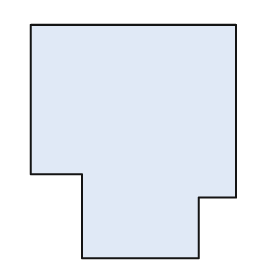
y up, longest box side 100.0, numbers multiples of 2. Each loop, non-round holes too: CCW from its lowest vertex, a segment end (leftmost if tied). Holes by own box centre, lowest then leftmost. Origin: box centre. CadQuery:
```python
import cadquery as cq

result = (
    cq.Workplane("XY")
    .moveTo(-22.0, -50.0)
    .lineTo(28.0, -50.0)
    .lineTo(28.0, -24.0)
    .lineTo(44.0, -24.0)
    .lineTo(44.0, 50.0)
    .lineTo(-44.0, 50.0)
    .lineTo(-44.0, -14.0)
    .lineTo(-22.0, -14.0)
    .close()
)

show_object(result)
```